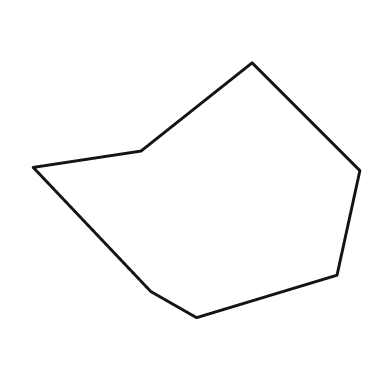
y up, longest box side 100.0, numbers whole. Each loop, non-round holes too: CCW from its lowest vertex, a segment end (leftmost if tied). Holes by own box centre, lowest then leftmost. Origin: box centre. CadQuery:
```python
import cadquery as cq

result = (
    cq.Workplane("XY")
    .moveTo(0.0, -39.0)
    .lineTo(43.0, -26.0)
    .lineTo(50.0, 6.0)
    .lineTo(17.0, 39.0)
    .lineTo(-17.0, 12.0)
    .lineTo(-50.0, 7.0)
    .lineTo(-14.0, -31.0)
    .close()
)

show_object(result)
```